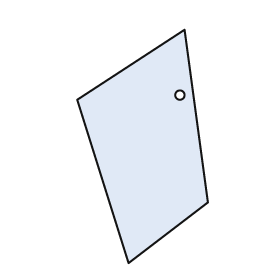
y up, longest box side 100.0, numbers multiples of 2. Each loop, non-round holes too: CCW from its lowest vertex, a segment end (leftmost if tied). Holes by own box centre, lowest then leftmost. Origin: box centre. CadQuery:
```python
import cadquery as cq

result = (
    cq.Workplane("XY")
    .moveTo(-6.0, -50.0)
    .lineTo(28.0, -24.0)
    .lineTo(18.0, 50.0)
    .lineTo(-28.0, 20.0)
    .close()
    .moveTo(16.0, 22.0)
    .circle(2.0)
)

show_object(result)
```